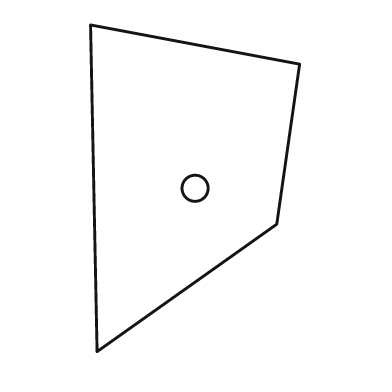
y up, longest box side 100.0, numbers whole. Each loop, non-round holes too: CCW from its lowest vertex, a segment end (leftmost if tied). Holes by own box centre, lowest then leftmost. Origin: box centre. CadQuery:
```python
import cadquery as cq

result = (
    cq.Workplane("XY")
    .moveTo(-30.0, -50.0)
    .lineTo(25.0, -11.0)
    .lineTo(32.0, 38.0)
    .lineTo(-32.0, 50.0)
    .close()
    .moveTo(0.0, 0.0)
    .circle(4.0)
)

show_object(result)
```